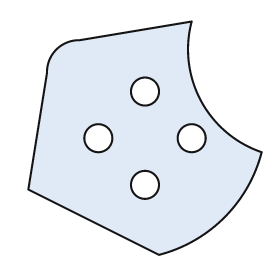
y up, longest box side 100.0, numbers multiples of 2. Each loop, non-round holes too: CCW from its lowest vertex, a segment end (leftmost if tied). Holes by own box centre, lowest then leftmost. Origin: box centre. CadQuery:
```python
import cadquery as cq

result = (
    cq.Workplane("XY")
    .moveTo(6.0, -50.0)
    .threePointArc((34.0, -34.0), (50.0, -6.0))
    .threePointArc((24.0, 16.0), (20.0, 50.0))
    .lineTo(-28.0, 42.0)
    .threePointArc((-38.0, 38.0), (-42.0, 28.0))
    .lineTo(-50.0, -22.0)
    .close()
    .moveTo(0.0, -20.0)
    .circle(6.0)
    .moveTo(-20.0, 0.0)
    .circle(6.0)
    .moveTo(20.0, 0.0)
    .circle(6.0)
    .moveTo(0.0, 20.0)
    .circle(6.0)
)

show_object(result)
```